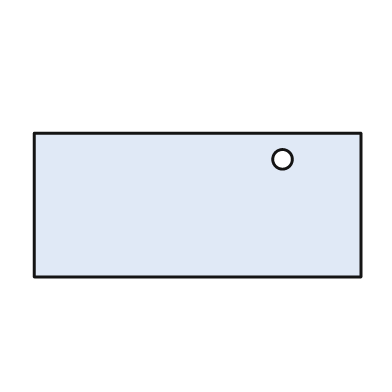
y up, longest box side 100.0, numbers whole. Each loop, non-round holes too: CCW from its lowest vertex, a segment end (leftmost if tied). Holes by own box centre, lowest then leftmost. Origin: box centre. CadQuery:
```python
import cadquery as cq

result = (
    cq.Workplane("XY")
    .moveTo(-50.0, -22.0)
    .lineTo(50.0, -22.0)
    .lineTo(50.0, 22.0)
    .lineTo(-50.0, 22.0)
    .close()
    .moveTo(26.0, 14.0)
    .circle(3.0)
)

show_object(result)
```